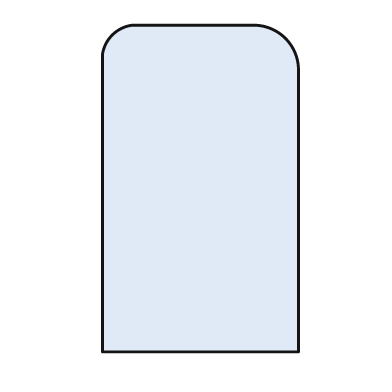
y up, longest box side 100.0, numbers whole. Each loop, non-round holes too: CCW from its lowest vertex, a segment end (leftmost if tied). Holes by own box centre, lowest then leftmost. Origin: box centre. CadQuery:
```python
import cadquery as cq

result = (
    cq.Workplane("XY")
    .moveTo(-30.0, -50.0)
    .lineTo(30.0, -50.0)
    .lineTo(30.0, 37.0)
    .threePointArc((26.0, 46.0), (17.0, 50.0))
    .lineTo(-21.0, 50.0)
    .threePointArc((-27.0, 47.0), (-30.0, 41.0))
    .close()
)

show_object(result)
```